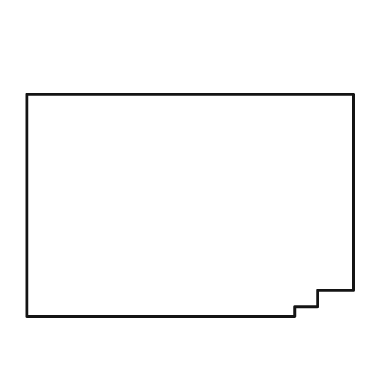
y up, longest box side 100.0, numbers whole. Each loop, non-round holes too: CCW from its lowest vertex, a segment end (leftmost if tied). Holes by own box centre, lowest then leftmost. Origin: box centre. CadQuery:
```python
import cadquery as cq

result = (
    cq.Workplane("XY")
    .moveTo(-50.0, -34.0)
    .lineTo(32.0, -34.0)
    .lineTo(32.0, -31.0)
    .lineTo(39.0, -31.0)
    .lineTo(39.0, -26.0)
    .lineTo(50.0, -26.0)
    .lineTo(50.0, 34.0)
    .lineTo(-50.0, 34.0)
    .close()
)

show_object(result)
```